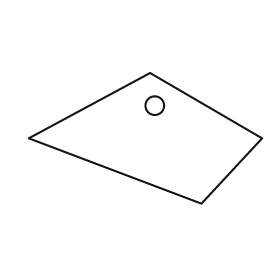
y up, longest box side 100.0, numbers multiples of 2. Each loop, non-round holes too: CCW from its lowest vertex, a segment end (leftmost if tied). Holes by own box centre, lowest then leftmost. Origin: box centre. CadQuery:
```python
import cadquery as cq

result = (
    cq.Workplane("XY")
    .moveTo(24.0, -28.0)
    .lineTo(50.0, 0.0)
    .lineTo(2.0, 28.0)
    .lineTo(-50.0, 0.0)
    .close()
    .moveTo(4.0, 14.0)
    .circle(4.0)
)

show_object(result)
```